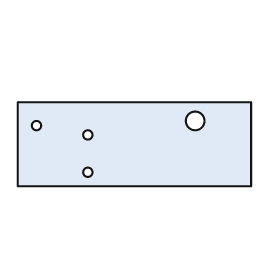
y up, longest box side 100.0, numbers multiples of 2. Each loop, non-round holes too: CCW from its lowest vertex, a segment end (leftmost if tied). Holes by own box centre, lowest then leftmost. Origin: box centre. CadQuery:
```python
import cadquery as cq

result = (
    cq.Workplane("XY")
    .moveTo(-50.0, -18.0)
    .lineTo(50.0, -18.0)
    .lineTo(50.0, 18.0)
    .lineTo(-50.0, 18.0)
    .close()
    .moveTo(-20.0, -12.0)
    .circle(2.0)
    .moveTo(-20.0, 4.0)
    .circle(2.0)
    .moveTo(-42.0, 8.0)
    .circle(2.0)
    .moveTo(26.0, 10.0)
    .circle(4.0)
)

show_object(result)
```